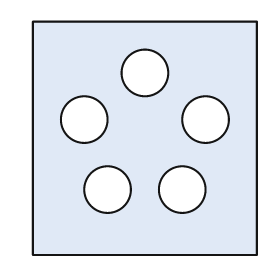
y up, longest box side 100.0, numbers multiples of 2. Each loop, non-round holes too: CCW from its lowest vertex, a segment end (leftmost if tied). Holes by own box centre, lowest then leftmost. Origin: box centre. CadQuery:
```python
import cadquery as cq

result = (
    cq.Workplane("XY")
    .moveTo(-48.0, -50.0)
    .lineTo(48.0, -50.0)
    .lineTo(48.0, 50.0)
    .lineTo(-48.0, 50.0)
    .close()
    .moveTo(-16.0, -22.0)
    .circle(10.0)
    .moveTo(16.0, -22.0)
    .circle(10.0)
    .moveTo(-26.0, 8.0)
    .circle(10.0)
    .moveTo(26.0, 8.0)
    .circle(10.0)
    .moveTo(0.0, 28.0)
    .circle(10.0)
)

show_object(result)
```